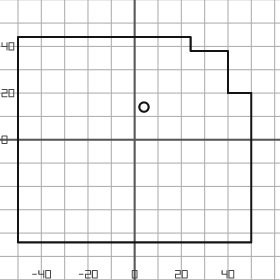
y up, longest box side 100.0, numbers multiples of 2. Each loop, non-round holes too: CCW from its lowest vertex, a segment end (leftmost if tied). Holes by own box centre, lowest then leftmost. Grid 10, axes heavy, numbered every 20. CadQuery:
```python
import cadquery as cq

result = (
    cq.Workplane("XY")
    .moveTo(-50.0, -44.0)
    .lineTo(50.0, -44.0)
    .lineTo(50.0, 20.0)
    .lineTo(40.0, 20.0)
    .lineTo(40.0, 38.0)
    .lineTo(24.0, 38.0)
    .lineTo(24.0, 44.0)
    .lineTo(-50.0, 44.0)
    .close()
    .moveTo(4.0, 14.0)
    .circle(2.0)
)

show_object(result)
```